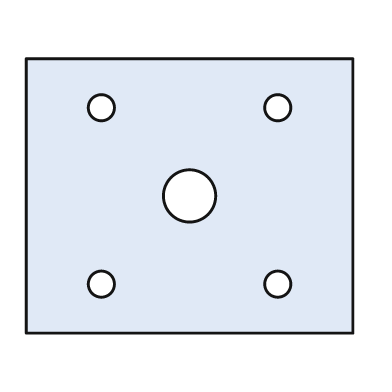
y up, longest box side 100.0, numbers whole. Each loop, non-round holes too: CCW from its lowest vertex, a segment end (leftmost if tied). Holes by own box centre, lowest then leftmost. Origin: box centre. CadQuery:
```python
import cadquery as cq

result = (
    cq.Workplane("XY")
    .moveTo(-50.0, -42.0)
    .lineTo(50.0, -42.0)
    .lineTo(50.0, 42.0)
    .lineTo(-50.0, 42.0)
    .close()
    .moveTo(-27.0, -27.0)
    .circle(4.0)
    .moveTo(27.0, -27.0)
    .circle(4.0)
    .moveTo(0.0, 0.0)
    .circle(8.0)
    .moveTo(-27.0, 27.0)
    .circle(4.0)
    .moveTo(27.0, 27.0)
    .circle(4.0)
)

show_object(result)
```